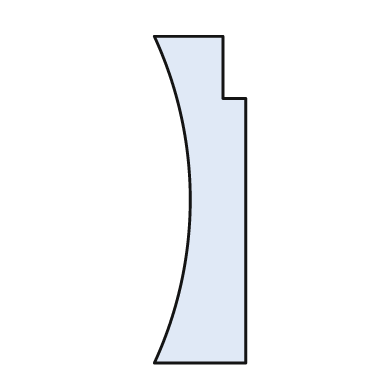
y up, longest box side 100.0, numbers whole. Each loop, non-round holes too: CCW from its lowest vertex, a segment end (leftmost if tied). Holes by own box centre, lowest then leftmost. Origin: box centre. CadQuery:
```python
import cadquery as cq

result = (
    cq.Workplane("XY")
    .moveTo(-14.0, -50.0)
    .lineTo(14.0, -50.0)
    .lineTo(14.0, 31.0)
    .lineTo(7.0, 31.0)
    .lineTo(7.0, 50.0)
    .lineTo(-14.0, 50.0)
    .threePointArc((-3.0, 0.0), (-14.0, -50.0))
    .close()
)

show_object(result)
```